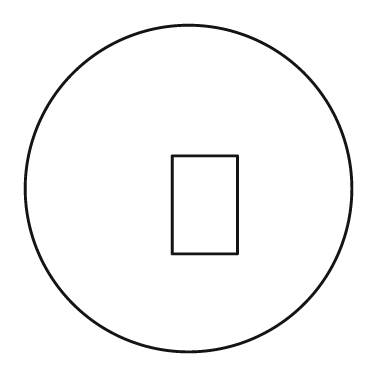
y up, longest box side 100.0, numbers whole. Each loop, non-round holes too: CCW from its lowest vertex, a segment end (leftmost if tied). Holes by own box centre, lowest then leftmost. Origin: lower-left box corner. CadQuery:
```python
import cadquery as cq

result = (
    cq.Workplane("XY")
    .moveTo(50.0, 50.0)
    .circle(50.0)
    .moveTo(45.0, 30.0)
    .lineTo(65.0, 30.0)
    .lineTo(65.0, 60.0)
    .lineTo(45.0, 60.0)
    .close()
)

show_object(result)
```